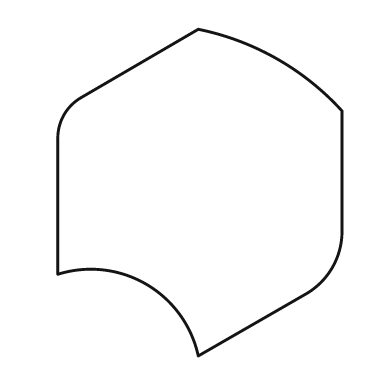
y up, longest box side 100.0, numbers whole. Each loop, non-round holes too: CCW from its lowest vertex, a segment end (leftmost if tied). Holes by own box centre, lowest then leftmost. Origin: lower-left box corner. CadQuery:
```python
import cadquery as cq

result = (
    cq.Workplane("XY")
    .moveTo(43.0, 0.0)
    .lineTo(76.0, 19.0)
    .threePointArc((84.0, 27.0), (87.0, 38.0))
    .lineTo(87.0, 75.0)
    .threePointArc((67.0, 91.0), (43.0, 100.0))
    .lineTo(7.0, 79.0)
    .threePointArc((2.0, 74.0), (0.0, 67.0))
    .lineTo(0.0, 25.0)
    .threePointArc((27.0, 22.0), (43.0, 0.0))
    .close()
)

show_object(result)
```